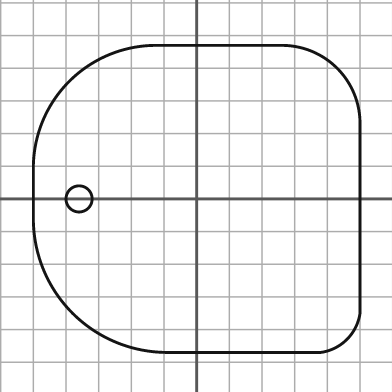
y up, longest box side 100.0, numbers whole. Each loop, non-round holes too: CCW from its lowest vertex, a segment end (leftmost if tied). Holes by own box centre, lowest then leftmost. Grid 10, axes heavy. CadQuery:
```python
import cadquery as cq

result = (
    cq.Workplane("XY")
    .moveTo(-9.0, -47.0)
    .lineTo(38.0, -47.0)
    .threePointArc((46.0, -43.0), (50.0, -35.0))
    .lineTo(50.0, 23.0)
    .threePointArc((43.0, 40.0), (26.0, 47.0))
    .lineTo(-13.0, 47.0)
    .threePointArc((-39.0, 36.0), (-50.0, 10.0))
    .lineTo(-50.0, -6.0)
    .threePointArc((-38.0, -35.0), (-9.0, -47.0))
    .close()
    .moveTo(-36.0, 0.0)
    .circle(4.0)
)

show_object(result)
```